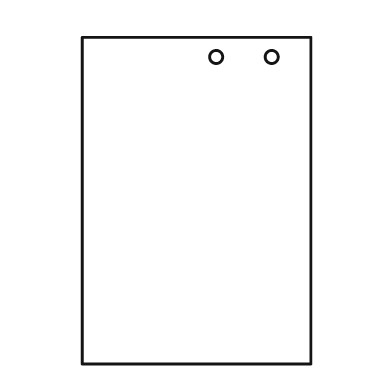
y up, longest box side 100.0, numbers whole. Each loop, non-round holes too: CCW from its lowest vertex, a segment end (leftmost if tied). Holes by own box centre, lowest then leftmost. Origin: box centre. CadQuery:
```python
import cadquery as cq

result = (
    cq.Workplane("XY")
    .moveTo(-35.0, -50.0)
    .lineTo(35.0, -50.0)
    .lineTo(35.0, 50.0)
    .lineTo(-35.0, 50.0)
    .close()
    .moveTo(6.0, 44.0)
    .circle(2.0)
    .moveTo(23.0, 44.0)
    .circle(2.0)
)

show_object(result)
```